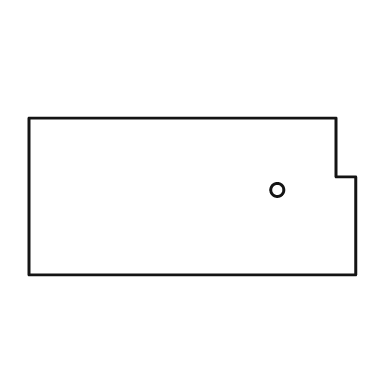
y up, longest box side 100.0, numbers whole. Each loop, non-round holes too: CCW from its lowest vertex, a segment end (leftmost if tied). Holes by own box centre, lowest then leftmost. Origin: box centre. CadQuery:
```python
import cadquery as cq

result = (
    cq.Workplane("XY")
    .moveTo(-50.0, -24.0)
    .lineTo(50.0, -24.0)
    .lineTo(50.0, 6.0)
    .lineTo(44.0, 6.0)
    .lineTo(44.0, 24.0)
    .lineTo(-50.0, 24.0)
    .close()
    .moveTo(26.0, 2.0)
    .circle(2.0)
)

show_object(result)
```